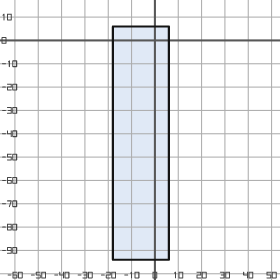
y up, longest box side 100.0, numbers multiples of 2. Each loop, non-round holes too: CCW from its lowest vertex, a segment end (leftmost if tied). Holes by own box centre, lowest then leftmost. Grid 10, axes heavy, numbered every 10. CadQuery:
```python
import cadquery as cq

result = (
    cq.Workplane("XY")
    .moveTo(-18.0, -94.0)
    .lineTo(6.0, -94.0)
    .lineTo(6.0, 6.0)
    .lineTo(-18.0, 6.0)
    .close()
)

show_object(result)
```